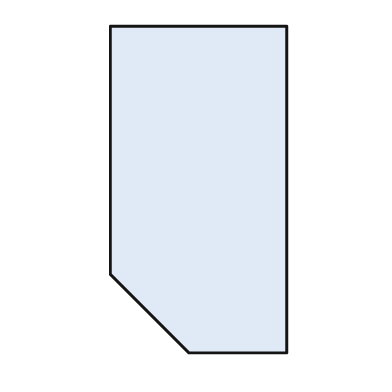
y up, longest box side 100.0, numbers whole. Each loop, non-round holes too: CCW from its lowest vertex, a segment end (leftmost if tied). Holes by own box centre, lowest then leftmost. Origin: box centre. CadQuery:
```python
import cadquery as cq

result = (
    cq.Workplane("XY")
    .moveTo(-3.0, -50.0)
    .lineTo(27.0, -50.0)
    .lineTo(27.0, 50.0)
    .lineTo(-27.0, 50.0)
    .lineTo(-27.0, -26.0)
    .close()
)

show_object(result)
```